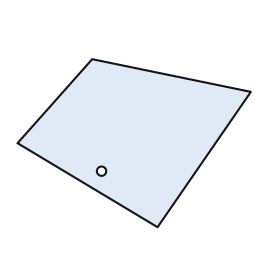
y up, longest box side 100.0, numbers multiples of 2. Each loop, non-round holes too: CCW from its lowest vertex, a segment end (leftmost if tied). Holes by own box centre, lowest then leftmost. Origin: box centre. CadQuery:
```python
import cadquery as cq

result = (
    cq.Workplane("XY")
    .moveTo(10.0, -36.0)
    .lineTo(50.0, 22.0)
    .lineTo(-18.0, 36.0)
    .lineTo(-50.0, 0.0)
    .close()
    .moveTo(-14.0, -12.0)
    .circle(2.0)
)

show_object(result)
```